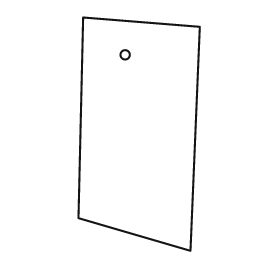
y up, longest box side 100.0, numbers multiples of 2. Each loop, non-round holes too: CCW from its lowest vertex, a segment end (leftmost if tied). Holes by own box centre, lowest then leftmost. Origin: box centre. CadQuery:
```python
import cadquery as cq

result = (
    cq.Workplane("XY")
    .moveTo(22.0, -50.0)
    .lineTo(26.0, 46.0)
    .lineTo(-24.0, 50.0)
    .lineTo(-26.0, -36.0)
    .close()
    .moveTo(-6.0, 34.0)
    .circle(2.0)
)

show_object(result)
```